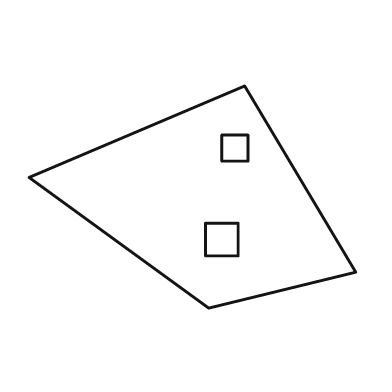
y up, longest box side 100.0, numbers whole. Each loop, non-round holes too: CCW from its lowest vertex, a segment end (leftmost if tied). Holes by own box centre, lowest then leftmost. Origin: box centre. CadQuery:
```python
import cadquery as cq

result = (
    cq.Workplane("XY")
    .moveTo(5.0, -34.0)
    .lineTo(50.0, -23.0)
    .lineTo(16.0, 34.0)
    .lineTo(-50.0, 6.0)
    .close()
    .moveTo(4.0, -18.0)
    .lineTo(14.0, -18.0)
    .lineTo(14.0, -8.0)
    .lineTo(4.0, -8.0)
    .close()
    .moveTo(9.0, 11.0)
    .lineTo(17.0, 11.0)
    .lineTo(17.0, 19.0)
    .lineTo(9.0, 19.0)
    .close()
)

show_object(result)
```